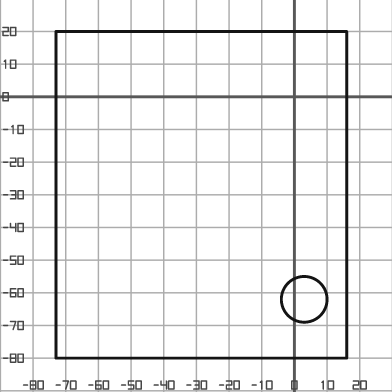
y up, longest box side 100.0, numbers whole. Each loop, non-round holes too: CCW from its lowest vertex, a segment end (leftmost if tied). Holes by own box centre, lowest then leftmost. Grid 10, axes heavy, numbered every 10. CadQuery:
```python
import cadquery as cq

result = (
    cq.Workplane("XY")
    .moveTo(-73.0, -80.0)
    .lineTo(16.0, -80.0)
    .lineTo(16.0, 20.0)
    .lineTo(-73.0, 20.0)
    .close()
    .moveTo(3.0, -62.0)
    .circle(7.0)
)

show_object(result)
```